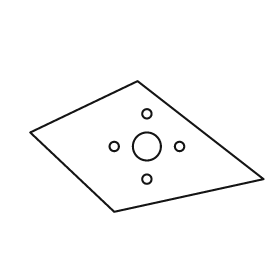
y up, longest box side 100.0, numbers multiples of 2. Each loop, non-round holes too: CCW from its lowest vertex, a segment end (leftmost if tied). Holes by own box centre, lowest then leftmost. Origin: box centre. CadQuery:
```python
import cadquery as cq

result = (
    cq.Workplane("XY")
    .moveTo(-14.0, -28.0)
    .lineTo(50.0, -14.0)
    .lineTo(-4.0, 28.0)
    .lineTo(-50.0, 6.0)
    .close()
    .moveTo(0.0, -14.0)
    .circle(2.0)
    .moveTo(-14.0, 0.0)
    .circle(2.0)
    .moveTo(0.0, 0.0)
    .circle(6.0)
    .moveTo(14.0, 0.0)
    .circle(2.0)
    .moveTo(0.0, 14.0)
    .circle(2.0)
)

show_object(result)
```